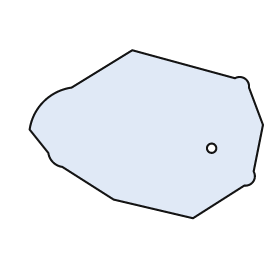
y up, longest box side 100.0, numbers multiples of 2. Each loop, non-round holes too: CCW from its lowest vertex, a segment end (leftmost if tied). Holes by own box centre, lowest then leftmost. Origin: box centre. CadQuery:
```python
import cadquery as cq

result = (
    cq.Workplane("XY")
    .moveTo(20.0, -36.0)
    .lineTo(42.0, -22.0)
    .threePointArc((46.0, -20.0), (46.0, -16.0))
    .lineTo(50.0, 4.0)
    .lineTo(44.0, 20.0)
    .threePointArc((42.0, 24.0), (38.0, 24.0))
    .lineTo(-6.0, 36.0)
    .lineTo(-32.0, 20.0)
    .threePointArc((-44.0, 14.0), (-50.0, 2.0))
    .lineTo(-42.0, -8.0)
    .threePointArc((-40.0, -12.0), (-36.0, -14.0))
    .lineTo(-14.0, -28.0)
    .close()
    .moveTo(28.0, -6.0)
    .circle(2.0)
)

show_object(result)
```